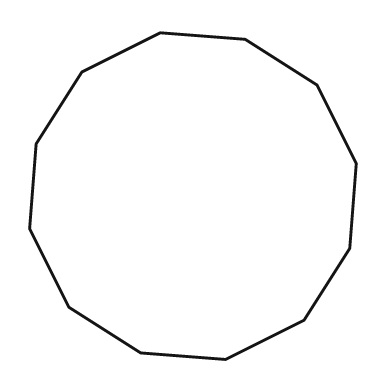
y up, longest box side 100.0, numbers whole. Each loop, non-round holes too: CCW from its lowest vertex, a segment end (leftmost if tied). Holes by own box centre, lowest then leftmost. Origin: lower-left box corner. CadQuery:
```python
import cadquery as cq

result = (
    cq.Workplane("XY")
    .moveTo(60.0, 0.0)
    .lineTo(84.0, 12.0)
    .lineTo(98.0, 34.0)
    .lineTo(100.0, 60.0)
    .lineTo(88.0, 84.0)
    .lineTo(66.0, 98.0)
    .lineTo(40.0, 100.0)
    .lineTo(16.0, 88.0)
    .lineTo(2.0, 66.0)
    .lineTo(0.0, 40.0)
    .lineTo(12.0, 16.0)
    .lineTo(34.0, 2.0)
    .close()
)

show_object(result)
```